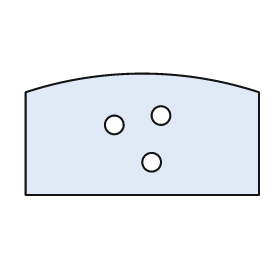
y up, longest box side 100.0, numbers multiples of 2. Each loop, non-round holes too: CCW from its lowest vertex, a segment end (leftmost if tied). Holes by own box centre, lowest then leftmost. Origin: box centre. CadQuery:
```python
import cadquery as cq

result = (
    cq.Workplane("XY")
    .moveTo(-50.0, -26.0)
    .lineTo(50.0, -26.0)
    .lineTo(50.0, 18.0)
    .threePointArc((0.0, 26.0), (-50.0, 18.0))
    .close()
    .moveTo(4.0, -12.0)
    .circle(4.0)
    .moveTo(-12.0, 4.0)
    .circle(4.0)
    .moveTo(8.0, 8.0)
    .circle(4.0)
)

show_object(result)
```